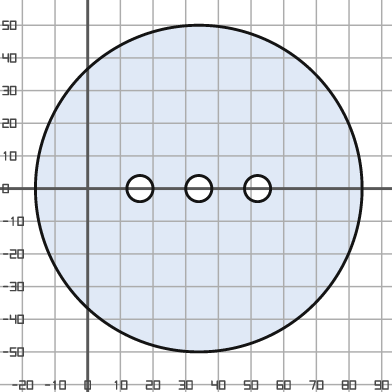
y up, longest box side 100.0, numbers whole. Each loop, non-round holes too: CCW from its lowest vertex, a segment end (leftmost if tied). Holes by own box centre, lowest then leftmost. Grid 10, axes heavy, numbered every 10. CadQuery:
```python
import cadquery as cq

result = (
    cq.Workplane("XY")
    .moveTo(34.0, 0.0)
    .circle(50.0)
    .moveTo(16.0, 0.0)
    .circle(4.0)
    .moveTo(34.0, 0.0)
    .circle(4.0)
    .moveTo(52.0, 0.0)
    .circle(4.0)
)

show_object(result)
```